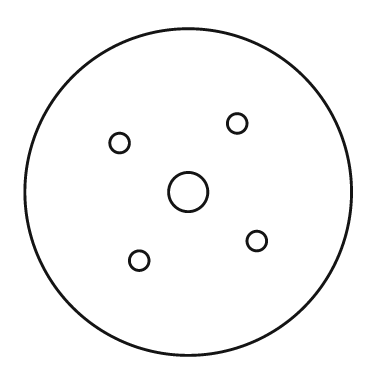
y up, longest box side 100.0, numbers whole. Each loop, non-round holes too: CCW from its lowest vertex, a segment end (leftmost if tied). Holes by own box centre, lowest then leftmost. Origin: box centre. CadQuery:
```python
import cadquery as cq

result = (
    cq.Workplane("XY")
    .moveTo(0.0, 0.0)
    .circle(50.0)
    .moveTo(-15.0, -21.0)
    .circle(3.0)
    .moveTo(21.0, -15.0)
    .circle(3.0)
    .moveTo(0.0, 0.0)
    .circle(6.0)
    .moveTo(-21.0, 15.0)
    .circle(3.0)
    .moveTo(15.0, 21.0)
    .circle(3.0)
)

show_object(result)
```